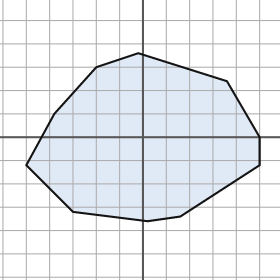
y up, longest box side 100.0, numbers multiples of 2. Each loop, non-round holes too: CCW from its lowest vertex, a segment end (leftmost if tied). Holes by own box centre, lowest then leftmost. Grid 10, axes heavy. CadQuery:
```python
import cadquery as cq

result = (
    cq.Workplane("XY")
    .moveTo(2.0, -36.0)
    .lineTo(16.0, -34.0)
    .lineTo(50.0, -12.0)
    .lineTo(50.0, 0.0)
    .lineTo(36.0, 24.0)
    .lineTo(-2.0, 36.0)
    .lineTo(-20.0, 30.0)
    .lineTo(-38.0, 10.0)
    .lineTo(-50.0, -12.0)
    .lineTo(-30.0, -32.0)
    .close()
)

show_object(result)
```